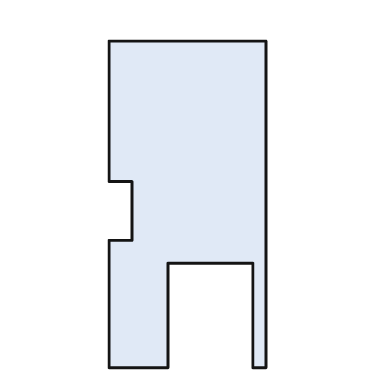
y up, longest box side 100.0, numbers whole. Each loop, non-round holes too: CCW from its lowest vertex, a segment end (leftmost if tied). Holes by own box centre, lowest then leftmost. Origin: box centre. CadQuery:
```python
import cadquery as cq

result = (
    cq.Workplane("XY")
    .moveTo(-24.0, -50.0)
    .lineTo(-6.0, -50.0)
    .lineTo(-6.0, -18.0)
    .lineTo(20.0, -18.0)
    .lineTo(20.0, -50.0)
    .lineTo(24.0, -50.0)
    .lineTo(24.0, 50.0)
    .lineTo(-24.0, 50.0)
    .lineTo(-24.0, 7.0)
    .lineTo(-17.0, 7.0)
    .lineTo(-17.0, -11.0)
    .lineTo(-24.0, -11.0)
    .close()
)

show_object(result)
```